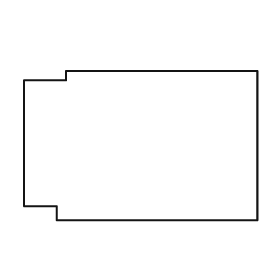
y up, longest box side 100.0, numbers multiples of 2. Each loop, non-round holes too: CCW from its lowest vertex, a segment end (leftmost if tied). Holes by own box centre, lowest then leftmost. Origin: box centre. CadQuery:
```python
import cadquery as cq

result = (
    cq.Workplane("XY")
    .moveTo(-36.0, -32.0)
    .lineTo(50.0, -32.0)
    .lineTo(50.0, 32.0)
    .lineTo(-32.0, 32.0)
    .lineTo(-32.0, 28.0)
    .lineTo(-50.0, 28.0)
    .lineTo(-50.0, -26.0)
    .lineTo(-36.0, -26.0)
    .close()
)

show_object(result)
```